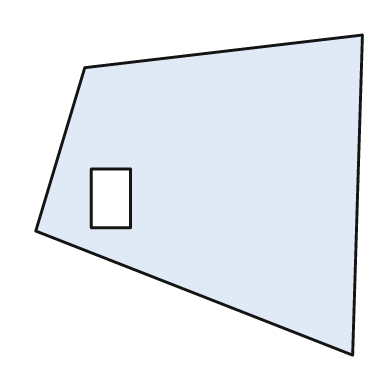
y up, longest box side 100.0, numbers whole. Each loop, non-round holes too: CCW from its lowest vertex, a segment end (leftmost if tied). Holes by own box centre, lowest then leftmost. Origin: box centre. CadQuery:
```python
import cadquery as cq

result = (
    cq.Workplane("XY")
    .moveTo(47.0, -49.0)
    .lineTo(50.0, 49.0)
    .lineTo(-35.0, 39.0)
    .lineTo(-50.0, -11.0)
    .close()
    .moveTo(-33.0, -10.0)
    .lineTo(-21.0, -10.0)
    .lineTo(-21.0, 8.0)
    .lineTo(-33.0, 8.0)
    .close()
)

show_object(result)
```